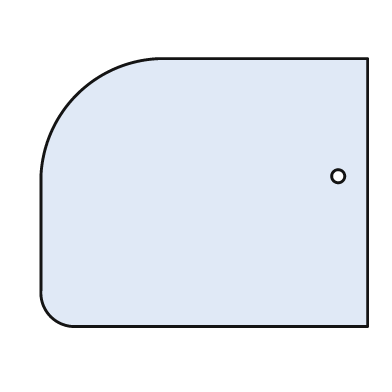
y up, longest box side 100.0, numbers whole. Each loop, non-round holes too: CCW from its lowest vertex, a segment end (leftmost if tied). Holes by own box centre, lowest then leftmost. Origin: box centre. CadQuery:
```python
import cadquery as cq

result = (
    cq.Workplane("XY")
    .moveTo(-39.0, -41.0)
    .lineTo(50.0, -41.0)
    .lineTo(50.0, 41.0)
    .lineTo(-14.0, 41.0)
    .threePointArc((-39.0, 30.0), (-50.0, 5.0))
    .lineTo(-50.0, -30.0)
    .threePointArc((-47.0, -38.0), (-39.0, -41.0))
    .close()
    .moveTo(41.0, 5.0)
    .circle(2.0)
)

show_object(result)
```